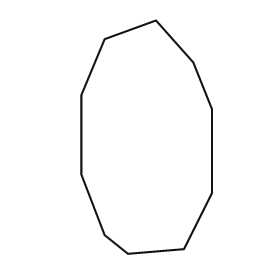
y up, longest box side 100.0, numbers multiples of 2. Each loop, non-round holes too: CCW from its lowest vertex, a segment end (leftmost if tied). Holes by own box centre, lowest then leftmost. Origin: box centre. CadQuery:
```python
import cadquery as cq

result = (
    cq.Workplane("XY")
    .moveTo(-8.0, -50.0)
    .lineTo(16.0, -48.0)
    .lineTo(28.0, -24.0)
    .lineTo(28.0, 12.0)
    .lineTo(20.0, 32.0)
    .lineTo(4.0, 50.0)
    .lineTo(-18.0, 42.0)
    .lineTo(-28.0, 18.0)
    .lineTo(-28.0, -16.0)
    .lineTo(-18.0, -42.0)
    .close()
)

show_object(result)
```